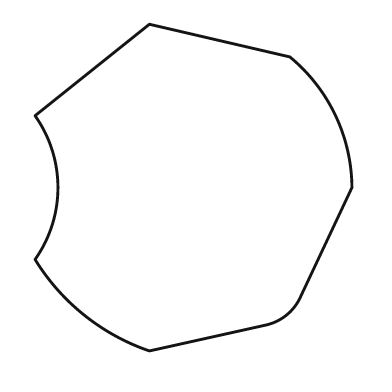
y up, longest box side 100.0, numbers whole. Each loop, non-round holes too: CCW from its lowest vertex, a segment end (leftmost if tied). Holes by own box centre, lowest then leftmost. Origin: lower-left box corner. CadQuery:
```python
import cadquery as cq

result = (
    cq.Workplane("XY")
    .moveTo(35.0, 0.0)
    .lineTo(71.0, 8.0)
    .threePointArc((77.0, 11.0), (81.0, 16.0))
    .lineTo(97.0, 50.0)
    .threePointArc((92.0, 72.0), (78.0, 90.0))
    .lineTo(35.0, 100.0)
    .lineTo(0.0, 72.0)
    .threePointArc((7.0, 50.0), (0.0, 28.0))
    .threePointArc((15.0, 11.0), (35.0, 0.0))
    .close()
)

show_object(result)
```